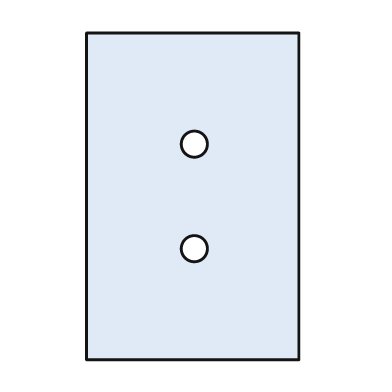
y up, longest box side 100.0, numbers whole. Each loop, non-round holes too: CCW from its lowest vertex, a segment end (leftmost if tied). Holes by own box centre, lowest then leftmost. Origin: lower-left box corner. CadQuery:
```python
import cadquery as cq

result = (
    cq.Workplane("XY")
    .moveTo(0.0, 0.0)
    .lineTo(65.0, 0.0)
    .lineTo(65.0, 100.0)
    .lineTo(0.0, 100.0)
    .close()
    .moveTo(33.0, 34.0)
    .circle(4.0)
    .moveTo(33.0, 66.0)
    .circle(4.0)
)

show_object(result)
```